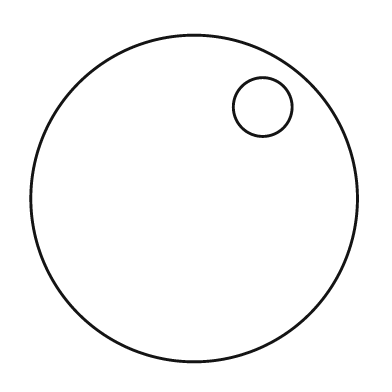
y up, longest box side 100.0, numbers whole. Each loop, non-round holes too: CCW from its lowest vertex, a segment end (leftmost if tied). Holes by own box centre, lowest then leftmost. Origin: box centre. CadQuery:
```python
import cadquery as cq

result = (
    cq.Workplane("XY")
    .moveTo(0.0, 0.0)
    .circle(50.0)
    .moveTo(21.0, 28.0)
    .circle(9.0)
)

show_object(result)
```